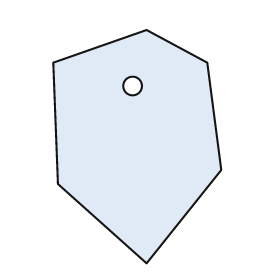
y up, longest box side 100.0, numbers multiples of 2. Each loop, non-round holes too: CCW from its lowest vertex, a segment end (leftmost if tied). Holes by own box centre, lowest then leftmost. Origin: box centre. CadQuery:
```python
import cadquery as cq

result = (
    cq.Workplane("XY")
    .moveTo(4.0, -50.0)
    .lineTo(36.0, -10.0)
    .lineTo(30.0, 36.0)
    .lineTo(4.0, 50.0)
    .lineTo(-36.0, 36.0)
    .lineTo(-34.0, -16.0)
    .close()
    .moveTo(-2.0, 26.0)
    .circle(4.0)
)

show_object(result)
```